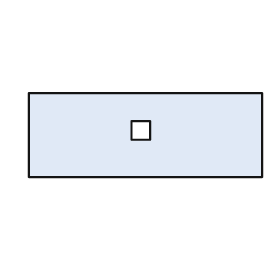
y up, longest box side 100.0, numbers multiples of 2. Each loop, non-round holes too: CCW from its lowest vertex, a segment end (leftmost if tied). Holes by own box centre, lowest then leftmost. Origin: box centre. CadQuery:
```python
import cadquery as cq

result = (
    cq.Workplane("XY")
    .moveTo(-50.0, -18.0)
    .lineTo(50.0, -18.0)
    .lineTo(50.0, 18.0)
    .lineTo(-50.0, 18.0)
    .close()
    .moveTo(-6.0, -2.0)
    .lineTo(2.0, -2.0)
    .lineTo(2.0, 6.0)
    .lineTo(-6.0, 6.0)
    .close()
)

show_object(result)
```